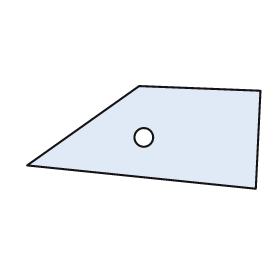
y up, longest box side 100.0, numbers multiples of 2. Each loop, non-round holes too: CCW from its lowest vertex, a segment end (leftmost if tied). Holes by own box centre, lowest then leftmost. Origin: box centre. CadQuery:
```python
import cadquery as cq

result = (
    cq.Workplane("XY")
    .moveTo(48.0, -22.0)
    .lineTo(50.0, 20.0)
    .lineTo(-2.0, 22.0)
    .lineTo(-50.0, -12.0)
    .close()
    .moveTo(0.0, 0.0)
    .circle(4.0)
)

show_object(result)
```